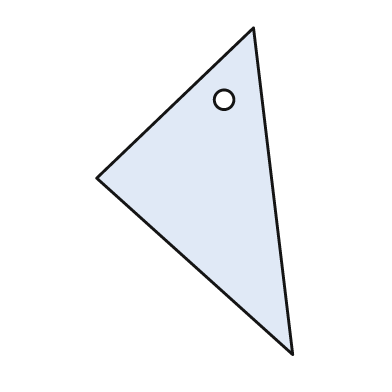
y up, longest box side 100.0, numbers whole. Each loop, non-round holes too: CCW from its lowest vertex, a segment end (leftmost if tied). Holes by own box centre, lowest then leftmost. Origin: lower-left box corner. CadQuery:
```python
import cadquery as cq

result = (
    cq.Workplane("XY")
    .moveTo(60.0, 0.0)
    .lineTo(48.0, 100.0)
    .lineTo(0.0, 54.0)
    .close()
    .moveTo(39.0, 78.0)
    .circle(3.0)
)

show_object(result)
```